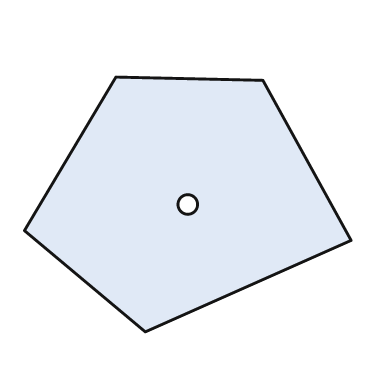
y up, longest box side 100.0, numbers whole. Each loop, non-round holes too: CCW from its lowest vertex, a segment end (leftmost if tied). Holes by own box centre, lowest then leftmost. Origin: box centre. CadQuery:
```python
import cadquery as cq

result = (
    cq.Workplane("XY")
    .moveTo(-13.0, -39.0)
    .lineTo(50.0, -11.0)
    .lineTo(23.0, 38.0)
    .lineTo(-22.0, 39.0)
    .lineTo(-50.0, -8.0)
    .close()
    .moveTo(0.0, 0.0)
    .circle(3.0)
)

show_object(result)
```